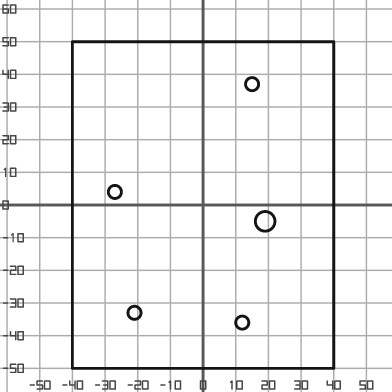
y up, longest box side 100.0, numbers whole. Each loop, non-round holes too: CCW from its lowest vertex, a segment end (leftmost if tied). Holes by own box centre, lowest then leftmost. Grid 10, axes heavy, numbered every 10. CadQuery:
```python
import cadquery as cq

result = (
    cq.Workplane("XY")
    .moveTo(-40.0, -50.0)
    .lineTo(40.0, -50.0)
    .lineTo(40.0, 50.0)
    .lineTo(-40.0, 50.0)
    .close()
    .moveTo(12.0, -36.0)
    .circle(2.0)
    .moveTo(-21.0, -33.0)
    .circle(2.0)
    .moveTo(19.0, -5.0)
    .circle(3.0)
    .moveTo(-27.0, 4.0)
    .circle(2.0)
    .moveTo(15.0, 37.0)
    .circle(2.0)
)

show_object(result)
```